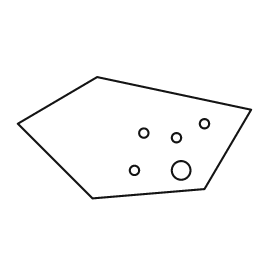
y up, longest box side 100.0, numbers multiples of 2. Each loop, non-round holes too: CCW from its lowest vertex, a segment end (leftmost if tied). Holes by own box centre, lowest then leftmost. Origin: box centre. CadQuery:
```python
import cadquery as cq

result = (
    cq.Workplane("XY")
    .moveTo(-18.0, -26.0)
    .lineTo(30.0, -22.0)
    .lineTo(50.0, 12.0)
    .lineTo(-16.0, 26.0)
    .lineTo(-50.0, 6.0)
    .close()
    .moveTo(0.0, -14.0)
    .circle(2.0)
    .moveTo(20.0, -14.0)
    .circle(4.0)
    .moveTo(18.0, 0.0)
    .circle(2.0)
    .moveTo(4.0, 2.0)
    .circle(2.0)
    .moveTo(30.0, 6.0)
    .circle(2.0)
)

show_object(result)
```